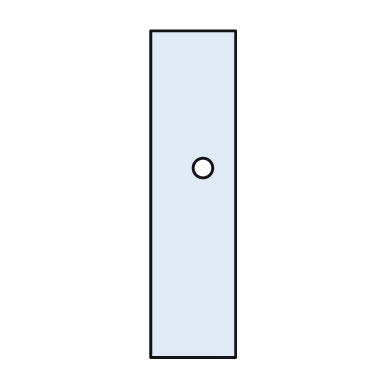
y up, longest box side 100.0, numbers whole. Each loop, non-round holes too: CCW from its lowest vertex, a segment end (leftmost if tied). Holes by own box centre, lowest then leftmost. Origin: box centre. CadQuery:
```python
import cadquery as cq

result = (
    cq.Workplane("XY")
    .moveTo(-13.0, -50.0)
    .lineTo(13.0, -50.0)
    .lineTo(13.0, 50.0)
    .lineTo(-13.0, 50.0)
    .close()
    .moveTo(3.0, 8.0)
    .circle(3.0)
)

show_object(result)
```